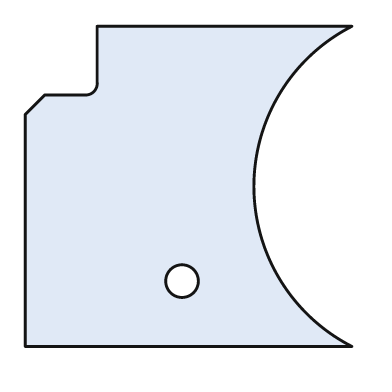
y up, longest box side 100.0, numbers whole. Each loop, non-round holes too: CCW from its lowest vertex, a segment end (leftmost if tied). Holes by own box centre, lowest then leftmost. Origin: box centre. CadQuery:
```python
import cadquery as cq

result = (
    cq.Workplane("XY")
    .moveTo(-50.0, -49.0)
    .lineTo(50.0, -49.0)
    .threePointArc((20.0, 0.0), (50.0, 49.0))
    .lineTo(-28.0, 49.0)
    .lineTo(-28.0, 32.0)
    .threePointArc((-29.0, 29.0), (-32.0, 28.0))
    .lineTo(-44.0, 28.0)
    .lineTo(-50.0, 22.0)
    .close()
    .moveTo(-2.0, -29.0)
    .circle(5.0)
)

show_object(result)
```